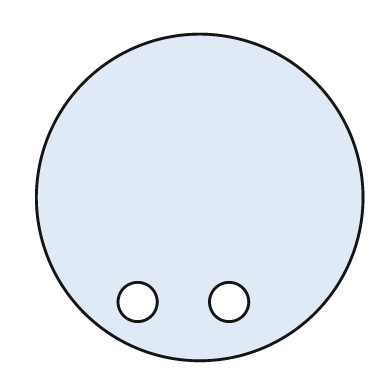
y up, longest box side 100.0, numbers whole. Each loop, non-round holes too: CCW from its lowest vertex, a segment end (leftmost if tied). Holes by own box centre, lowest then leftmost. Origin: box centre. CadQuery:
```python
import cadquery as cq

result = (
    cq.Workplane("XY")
    .moveTo(0.0, 0.0)
    .circle(50.0)
    .moveTo(-19.0, -32.0)
    .circle(6.0)
    .moveTo(9.0, -32.0)
    .circle(6.0)
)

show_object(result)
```